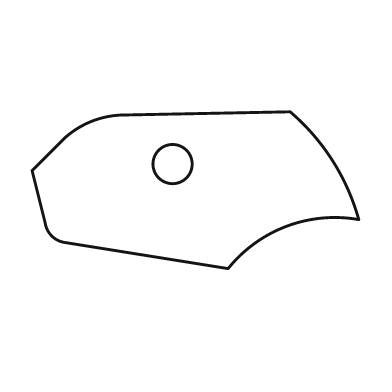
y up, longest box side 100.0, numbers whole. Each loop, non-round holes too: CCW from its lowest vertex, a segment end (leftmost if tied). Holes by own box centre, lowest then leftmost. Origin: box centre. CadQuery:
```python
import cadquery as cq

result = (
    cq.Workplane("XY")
    .moveTo(10.0, -24.0)
    .threePointArc((28.0, -11.0), (50.0, -9.0))
    .threePointArc((42.0, 9.0), (29.0, 24.0))
    .lineTo(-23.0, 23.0)
    .threePointArc((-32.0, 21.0), (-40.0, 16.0))
    .lineTo(-50.0, 6.0)
    .lineTo(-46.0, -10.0)
    .threePointArc((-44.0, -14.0), (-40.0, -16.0))
    .close()
    .moveTo(-7.0, 8.0)
    .circle(6.0)
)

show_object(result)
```